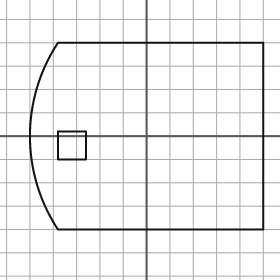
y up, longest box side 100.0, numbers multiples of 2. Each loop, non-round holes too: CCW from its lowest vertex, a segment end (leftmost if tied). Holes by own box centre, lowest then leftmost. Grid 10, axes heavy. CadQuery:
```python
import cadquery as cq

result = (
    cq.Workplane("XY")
    .moveTo(-38.0, -40.0)
    .lineTo(50.0, -40.0)
    .lineTo(50.0, 40.0)
    .lineTo(-38.0, 40.0)
    .threePointArc((-50.0, 0.0), (-38.0, -40.0))
    .close()
    .moveTo(-38.0, -10.0)
    .lineTo(-26.0, -10.0)
    .lineTo(-26.0, 2.0)
    .lineTo(-38.0, 2.0)
    .close()
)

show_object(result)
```